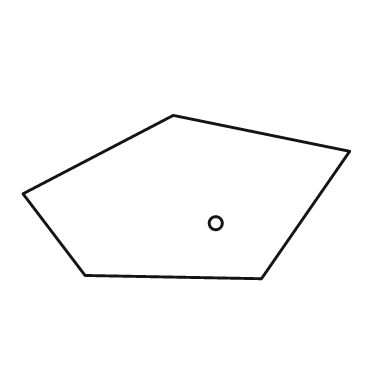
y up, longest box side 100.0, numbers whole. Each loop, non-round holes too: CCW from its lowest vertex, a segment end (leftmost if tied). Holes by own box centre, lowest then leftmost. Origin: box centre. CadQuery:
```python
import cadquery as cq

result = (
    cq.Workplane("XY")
    .moveTo(23.0, -25.0)
    .lineTo(50.0, 14.0)
    .lineTo(-4.0, 25.0)
    .lineTo(-50.0, 1.0)
    .lineTo(-31.0, -24.0)
    .close()
    .moveTo(9.0, -8.0)
    .circle(2.0)
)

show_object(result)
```